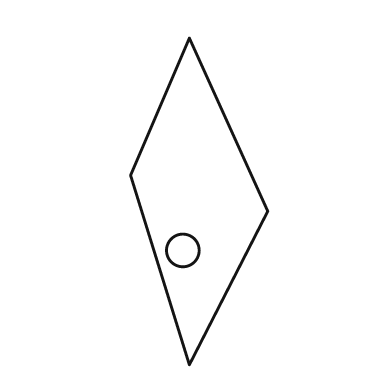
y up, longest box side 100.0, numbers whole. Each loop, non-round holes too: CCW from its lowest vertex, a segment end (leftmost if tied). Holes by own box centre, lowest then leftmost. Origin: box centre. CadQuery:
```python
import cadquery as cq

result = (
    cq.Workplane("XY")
    .moveTo(-3.0, -50.0)
    .lineTo(21.0, -3.0)
    .lineTo(-3.0, 50.0)
    .lineTo(-21.0, 8.0)
    .close()
    .moveTo(-5.0, -15.0)
    .circle(5.0)
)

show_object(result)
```